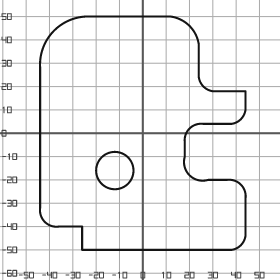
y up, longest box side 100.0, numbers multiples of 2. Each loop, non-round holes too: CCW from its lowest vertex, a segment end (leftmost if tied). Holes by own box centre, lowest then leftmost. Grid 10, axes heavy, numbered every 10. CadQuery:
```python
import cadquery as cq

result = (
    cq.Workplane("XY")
    .moveTo(-26.0, -50.0)
    .lineTo(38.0, -50.0)
    .threePointArc((42.0, -48.0), (44.0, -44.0))
    .lineTo(44.0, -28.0)
    .threePointArc((42.0, -22.0), (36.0, -20.0))
    .lineTo(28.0, -20.0)
    .threePointArc((20.0, -18.0), (18.0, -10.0))
    .lineTo(18.0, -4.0)
    .threePointArc((20.0, 2.0), (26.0, 4.0))
    .lineTo(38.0, 4.0)
    .threePointArc((42.0, 6.0), (44.0, 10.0))
    .lineTo(44.0, 18.0)
    .lineTo(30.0, 18.0)
    .threePointArc((26.0, 20.0), (24.0, 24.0))
    .lineTo(24.0, 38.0)
    .threePointArc((20.0, 46.0), (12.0, 50.0))
    .lineTo(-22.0, 50.0)
    .threePointArc((-38.0, 44.0), (-44.0, 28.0))
    .lineTo(-44.0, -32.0)
    .threePointArc((-42.0, -38.0), (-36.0, -40.0))
    .lineTo(-26.0, -40.0)
    .close()
    .moveTo(-12.0, -16.0)
    .circle(8.0)
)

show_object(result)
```